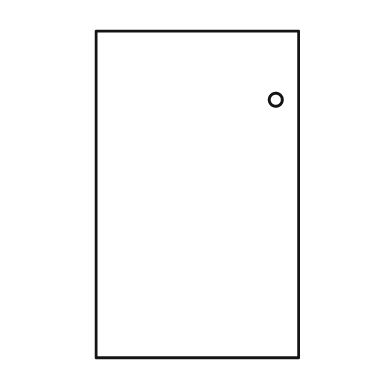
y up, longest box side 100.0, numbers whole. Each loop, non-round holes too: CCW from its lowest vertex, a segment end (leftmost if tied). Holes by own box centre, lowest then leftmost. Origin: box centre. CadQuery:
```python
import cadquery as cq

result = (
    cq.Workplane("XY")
    .moveTo(-31.0, -50.0)
    .lineTo(31.0, -50.0)
    .lineTo(31.0, 50.0)
    .lineTo(-31.0, 50.0)
    .close()
    .moveTo(24.0, 29.0)
    .circle(2.0)
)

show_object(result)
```